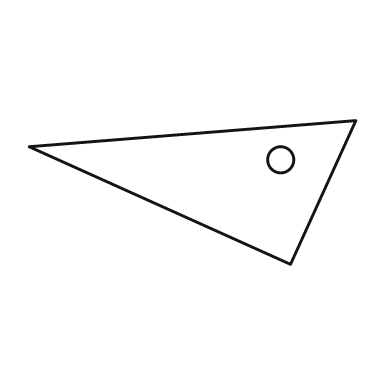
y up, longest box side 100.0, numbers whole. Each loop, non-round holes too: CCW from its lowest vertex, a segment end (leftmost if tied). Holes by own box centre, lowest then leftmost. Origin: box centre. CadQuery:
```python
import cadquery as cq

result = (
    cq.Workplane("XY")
    .moveTo(30.0, -22.0)
    .lineTo(50.0, 22.0)
    .lineTo(-50.0, 14.0)
    .close()
    .moveTo(27.0, 10.0)
    .circle(4.0)
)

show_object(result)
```